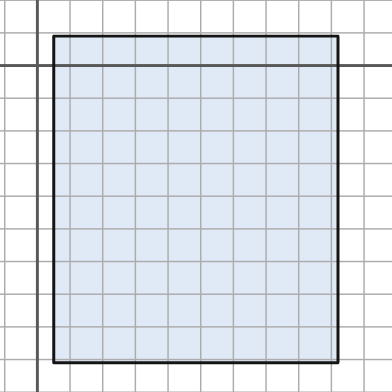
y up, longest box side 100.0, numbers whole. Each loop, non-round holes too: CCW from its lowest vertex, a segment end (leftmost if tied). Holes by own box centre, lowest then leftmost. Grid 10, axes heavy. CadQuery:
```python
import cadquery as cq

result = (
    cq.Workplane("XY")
    .moveTo(5.0, -91.0)
    .lineTo(92.0, -91.0)
    .lineTo(92.0, 9.0)
    .lineTo(5.0, 9.0)
    .close()
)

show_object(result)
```